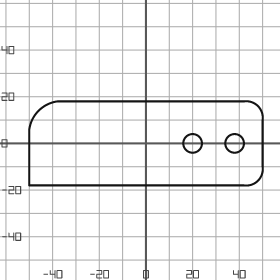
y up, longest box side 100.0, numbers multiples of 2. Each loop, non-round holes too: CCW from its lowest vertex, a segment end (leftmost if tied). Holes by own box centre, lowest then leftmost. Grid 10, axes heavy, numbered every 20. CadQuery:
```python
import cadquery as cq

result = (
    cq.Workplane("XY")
    .moveTo(-50.0, -18.0)
    .lineTo(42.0, -18.0)
    .threePointArc((48.0, -16.0), (50.0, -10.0))
    .lineTo(50.0, 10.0)
    .threePointArc((48.0, 16.0), (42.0, 18.0))
    .lineTo(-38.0, 18.0)
    .threePointArc((-46.0, 14.0), (-50.0, 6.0))
    .close()
    .moveTo(20.0, 0.0)
    .circle(4.0)
    .moveTo(38.0, 0.0)
    .circle(4.0)
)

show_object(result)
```